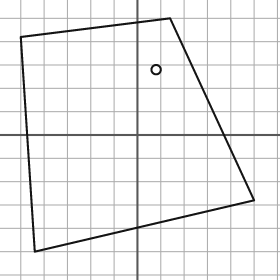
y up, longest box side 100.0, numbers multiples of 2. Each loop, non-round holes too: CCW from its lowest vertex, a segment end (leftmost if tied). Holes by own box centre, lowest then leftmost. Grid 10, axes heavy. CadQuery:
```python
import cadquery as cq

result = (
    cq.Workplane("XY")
    .moveTo(-44.0, -50.0)
    .lineTo(50.0, -28.0)
    .lineTo(14.0, 50.0)
    .lineTo(-50.0, 42.0)
    .close()
    .moveTo(8.0, 28.0)
    .circle(2.0)
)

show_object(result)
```